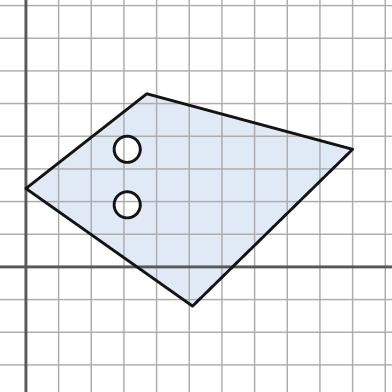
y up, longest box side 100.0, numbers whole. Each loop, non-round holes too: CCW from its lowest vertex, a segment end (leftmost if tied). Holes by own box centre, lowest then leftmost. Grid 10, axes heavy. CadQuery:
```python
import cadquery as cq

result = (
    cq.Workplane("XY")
    .moveTo(51.0, -12.0)
    .lineTo(100.0, 36.0)
    .lineTo(37.0, 53.0)
    .lineTo(0.0, 24.0)
    .close()
    .moveTo(31.0, 19.0)
    .circle(4.0)
    .moveTo(31.0, 36.0)
    .circle(4.0)
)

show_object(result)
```